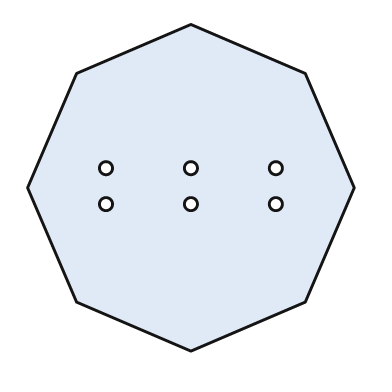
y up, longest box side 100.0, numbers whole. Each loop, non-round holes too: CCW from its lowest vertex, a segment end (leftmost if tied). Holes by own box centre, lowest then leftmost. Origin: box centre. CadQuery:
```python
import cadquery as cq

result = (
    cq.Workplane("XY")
    .moveTo(0.0, -50.0)
    .lineTo(35.0, -35.0)
    .lineTo(50.0, 0.0)
    .lineTo(35.0, 35.0)
    .lineTo(0.0, 50.0)
    .lineTo(-35.0, 35.0)
    .lineTo(-50.0, 0.0)
    .lineTo(-35.0, -35.0)
    .close()
    .moveTo(-26.0, -5.0)
    .circle(2.0)
    .moveTo(0.0, -5.0)
    .circle(2.0)
    .moveTo(26.0, -5.0)
    .circle(2.0)
    .moveTo(-26.0, 6.0)
    .circle(2.0)
    .moveTo(0.0, 6.0)
    .circle(2.0)
    .moveTo(26.0, 6.0)
    .circle(2.0)
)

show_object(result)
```